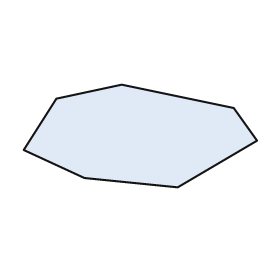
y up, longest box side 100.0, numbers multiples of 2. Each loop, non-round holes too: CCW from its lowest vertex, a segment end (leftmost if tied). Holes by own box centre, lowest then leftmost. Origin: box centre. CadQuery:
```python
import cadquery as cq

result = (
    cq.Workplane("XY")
    .moveTo(16.0, -22.0)
    .lineTo(50.0, -2.0)
    .lineTo(40.0, 12.0)
    .lineTo(-8.0, 22.0)
    .lineTo(-36.0, 16.0)
    .lineTo(-50.0, -6.0)
    .lineTo(-24.0, -18.0)
    .close()
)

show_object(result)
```